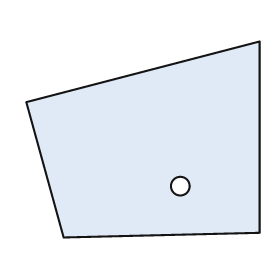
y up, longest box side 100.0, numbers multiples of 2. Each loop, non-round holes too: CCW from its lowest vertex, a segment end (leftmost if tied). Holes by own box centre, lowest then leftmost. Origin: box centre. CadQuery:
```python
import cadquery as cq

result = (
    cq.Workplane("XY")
    .moveTo(-34.0, -42.0)
    .lineTo(50.0, -40.0)
    .lineTo(50.0, 42.0)
    .lineTo(-50.0, 16.0)
    .close()
    .moveTo(16.0, -20.0)
    .circle(4.0)
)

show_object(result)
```